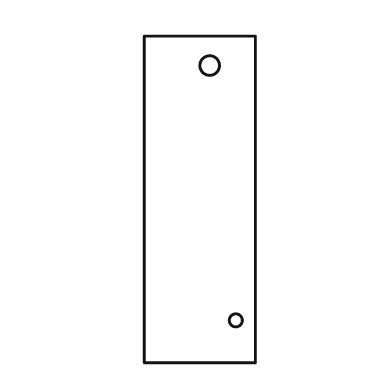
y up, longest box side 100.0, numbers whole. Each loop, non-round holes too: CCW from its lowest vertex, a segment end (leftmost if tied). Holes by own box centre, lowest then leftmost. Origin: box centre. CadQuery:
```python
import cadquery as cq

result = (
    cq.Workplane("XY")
    .moveTo(-17.0, -50.0)
    .lineTo(17.0, -50.0)
    .lineTo(17.0, 50.0)
    .lineTo(-17.0, 50.0)
    .close()
    .moveTo(11.0, -37.0)
    .circle(2.0)
    .moveTo(3.0, 41.0)
    .circle(3.0)
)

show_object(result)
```